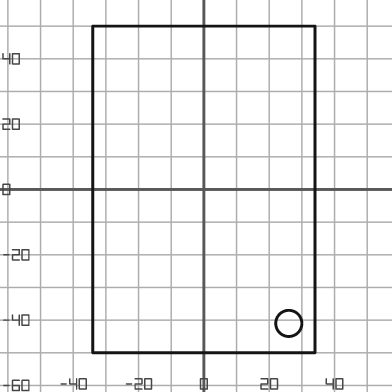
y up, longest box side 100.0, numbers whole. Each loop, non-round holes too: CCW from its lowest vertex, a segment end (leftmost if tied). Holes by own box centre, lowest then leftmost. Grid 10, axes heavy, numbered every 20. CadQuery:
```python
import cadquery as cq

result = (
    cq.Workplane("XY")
    .moveTo(-34.0, -50.0)
    .lineTo(34.0, -50.0)
    .lineTo(34.0, 50.0)
    .lineTo(-34.0, 50.0)
    .close()
    .moveTo(26.0, -41.0)
    .circle(4.0)
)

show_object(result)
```